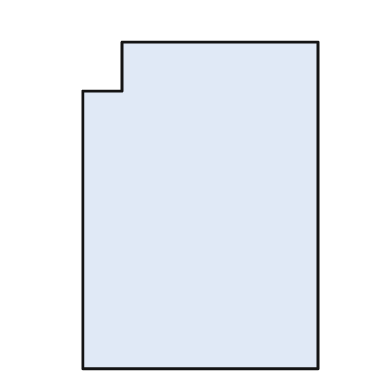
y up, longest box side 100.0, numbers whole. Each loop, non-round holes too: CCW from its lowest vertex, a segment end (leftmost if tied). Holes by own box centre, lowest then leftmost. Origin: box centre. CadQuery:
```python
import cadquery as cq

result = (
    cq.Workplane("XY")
    .moveTo(-36.0, -50.0)
    .lineTo(36.0, -50.0)
    .lineTo(36.0, 50.0)
    .lineTo(-24.0, 50.0)
    .lineTo(-24.0, 35.0)
    .lineTo(-36.0, 35.0)
    .close()
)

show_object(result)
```